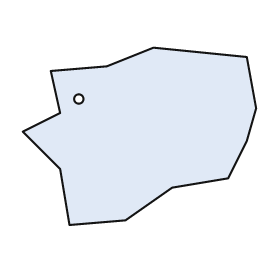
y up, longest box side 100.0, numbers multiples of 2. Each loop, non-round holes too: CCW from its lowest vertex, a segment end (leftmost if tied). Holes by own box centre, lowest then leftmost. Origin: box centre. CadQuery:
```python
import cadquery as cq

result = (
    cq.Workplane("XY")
    .moveTo(-30.0, -38.0)
    .lineTo(-6.0, -36.0)
    .lineTo(14.0, -22.0)
    .lineTo(38.0, -18.0)
    .lineTo(46.0, -2.0)
    .lineTo(50.0, 12.0)
    .lineTo(46.0, 34.0)
    .lineTo(6.0, 38.0)
    .lineTo(-14.0, 30.0)
    .lineTo(-38.0, 28.0)
    .lineTo(-34.0, 10.0)
    .lineTo(-50.0, 2.0)
    .lineTo(-34.0, -14.0)
    .close()
    .moveTo(-26.0, 16.0)
    .circle(2.0)
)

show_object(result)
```